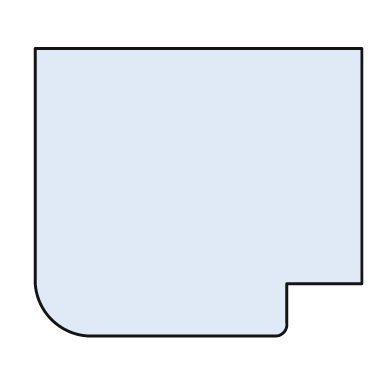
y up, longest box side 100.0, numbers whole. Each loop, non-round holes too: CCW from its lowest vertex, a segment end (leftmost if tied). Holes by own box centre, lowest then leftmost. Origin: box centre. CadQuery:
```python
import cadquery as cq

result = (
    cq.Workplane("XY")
    .moveTo(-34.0, -44.0)
    .lineTo(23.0, -44.0)
    .threePointArc((26.0, -43.0), (27.0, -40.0))
    .lineTo(27.0, -28.0)
    .lineTo(50.0, -28.0)
    .lineTo(50.0, 44.0)
    .lineTo(-50.0, 44.0)
    .lineTo(-50.0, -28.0)
    .threePointArc((-45.0, -39.0), (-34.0, -44.0))
    .close()
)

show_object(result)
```